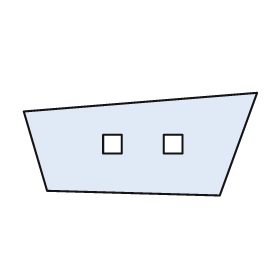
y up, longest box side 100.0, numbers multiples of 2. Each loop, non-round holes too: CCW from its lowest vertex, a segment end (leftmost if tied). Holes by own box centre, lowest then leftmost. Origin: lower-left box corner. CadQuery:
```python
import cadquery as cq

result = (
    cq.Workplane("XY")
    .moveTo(84.0, 0.0)
    .lineTo(100.0, 44.0)
    .lineTo(0.0, 36.0)
    .lineTo(10.0, 2.0)
    .close()
    .moveTo(34.0, 18.0)
    .lineTo(42.0, 18.0)
    .lineTo(42.0, 26.0)
    .lineTo(34.0, 26.0)
    .close()
    .moveTo(60.0, 18.0)
    .lineTo(68.0, 18.0)
    .lineTo(68.0, 26.0)
    .lineTo(60.0, 26.0)
    .close()
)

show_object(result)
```